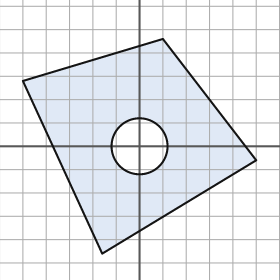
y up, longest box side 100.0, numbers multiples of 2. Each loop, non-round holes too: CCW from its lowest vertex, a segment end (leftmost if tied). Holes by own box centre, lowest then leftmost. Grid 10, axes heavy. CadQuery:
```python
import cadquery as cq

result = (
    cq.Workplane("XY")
    .moveTo(-16.0, -46.0)
    .lineTo(50.0, -6.0)
    .lineTo(10.0, 46.0)
    .lineTo(-50.0, 28.0)
    .close()
    .moveTo(0.0, 0.0)
    .circle(12.0)
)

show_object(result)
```